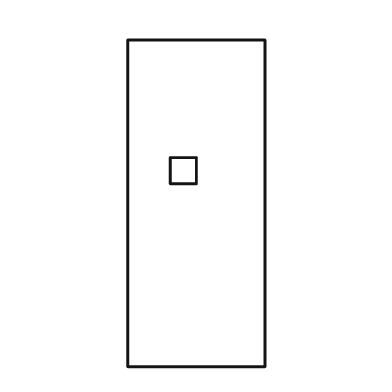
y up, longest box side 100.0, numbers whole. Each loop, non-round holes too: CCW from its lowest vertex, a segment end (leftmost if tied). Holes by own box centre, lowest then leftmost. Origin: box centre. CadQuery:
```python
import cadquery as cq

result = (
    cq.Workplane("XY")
    .moveTo(-21.0, -50.0)
    .lineTo(21.0, -50.0)
    .lineTo(21.0, 50.0)
    .lineTo(-21.0, 50.0)
    .close()
    .moveTo(-8.0, 6.0)
    .lineTo(0.0, 6.0)
    .lineTo(0.0, 14.0)
    .lineTo(-8.0, 14.0)
    .close()
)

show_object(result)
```